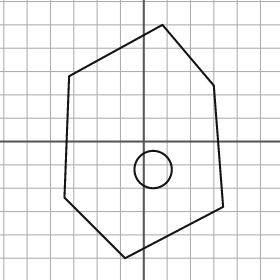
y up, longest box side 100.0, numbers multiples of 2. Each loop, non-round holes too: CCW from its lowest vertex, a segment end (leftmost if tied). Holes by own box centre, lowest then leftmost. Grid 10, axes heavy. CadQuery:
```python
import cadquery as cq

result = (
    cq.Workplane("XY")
    .moveTo(-8.0, -50.0)
    .lineTo(34.0, -28.0)
    .lineTo(30.0, 24.0)
    .lineTo(8.0, 50.0)
    .lineTo(-32.0, 28.0)
    .lineTo(-34.0, -24.0)
    .close()
    .moveTo(4.0, -12.0)
    .circle(8.0)
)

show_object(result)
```